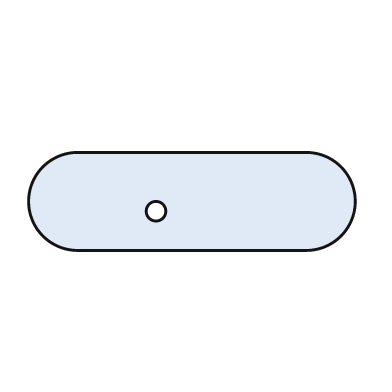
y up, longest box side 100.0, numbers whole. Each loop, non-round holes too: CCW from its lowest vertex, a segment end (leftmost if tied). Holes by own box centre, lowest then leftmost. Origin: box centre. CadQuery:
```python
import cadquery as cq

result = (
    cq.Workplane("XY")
    .moveTo(-35.0, -15.0)
    .lineTo(35.0, -15.0)
    .threePointArc((50.0, 0.0), (35.0, 15.0))
    .lineTo(-35.0, 15.0)
    .threePointArc((-50.0, 0.0), (-35.0, -15.0))
    .close()
    .moveTo(-11.0, -3.0)
    .circle(3.0)
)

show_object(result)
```